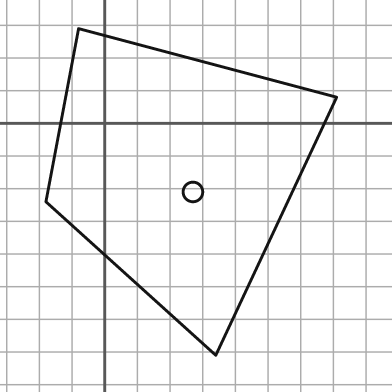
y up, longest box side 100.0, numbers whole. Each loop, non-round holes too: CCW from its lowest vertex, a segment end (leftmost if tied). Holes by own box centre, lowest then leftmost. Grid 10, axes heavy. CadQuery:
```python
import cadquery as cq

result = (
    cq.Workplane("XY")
    .moveTo(34.0, -71.0)
    .lineTo(71.0, 8.0)
    .lineTo(-8.0, 29.0)
    .lineTo(-18.0, -24.0)
    .close()
    .moveTo(27.0, -21.0)
    .circle(3.0)
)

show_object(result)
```